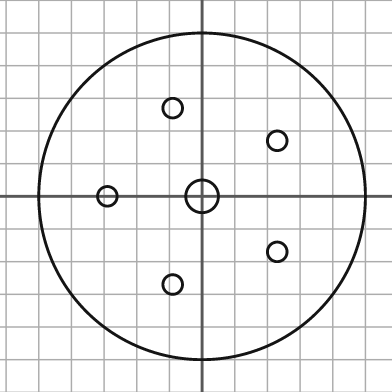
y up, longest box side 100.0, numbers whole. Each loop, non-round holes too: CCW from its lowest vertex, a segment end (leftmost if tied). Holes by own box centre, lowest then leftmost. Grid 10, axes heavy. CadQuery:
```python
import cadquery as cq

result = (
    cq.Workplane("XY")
    .moveTo(0.0, 0.0)
    .circle(50.0)
    .moveTo(-9.0, -27.0)
    .circle(3.0)
    .moveTo(23.0, -17.0)
    .circle(3.0)
    .moveTo(-29.0, 0.0)
    .circle(3.0)
    .moveTo(0.0, 0.0)
    .circle(5.0)
    .moveTo(23.0, 17.0)
    .circle(3.0)
    .moveTo(-9.0, 27.0)
    .circle(3.0)
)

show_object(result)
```